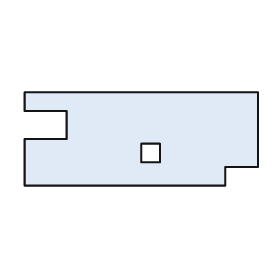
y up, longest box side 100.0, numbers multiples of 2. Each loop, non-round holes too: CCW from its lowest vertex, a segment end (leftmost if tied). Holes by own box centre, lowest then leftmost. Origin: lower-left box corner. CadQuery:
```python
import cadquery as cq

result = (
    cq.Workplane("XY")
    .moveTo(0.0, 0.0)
    .lineTo(86.0, 0.0)
    .lineTo(86.0, 8.0)
    .lineTo(100.0, 8.0)
    .lineTo(100.0, 40.0)
    .lineTo(0.0, 40.0)
    .lineTo(0.0, 32.0)
    .lineTo(18.0, 32.0)
    .lineTo(18.0, 20.0)
    .lineTo(0.0, 20.0)
    .close()
    .moveTo(50.0, 10.0)
    .lineTo(58.0, 10.0)
    .lineTo(58.0, 18.0)
    .lineTo(50.0, 18.0)
    .close()
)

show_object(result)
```